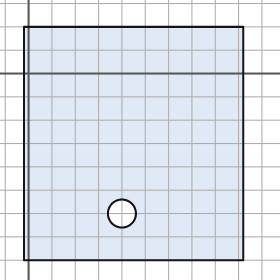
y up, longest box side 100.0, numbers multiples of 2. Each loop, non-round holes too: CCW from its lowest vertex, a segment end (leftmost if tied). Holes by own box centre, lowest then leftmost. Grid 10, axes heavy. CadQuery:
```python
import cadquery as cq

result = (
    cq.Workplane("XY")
    .moveTo(-2.0, -80.0)
    .lineTo(92.0, -80.0)
    .lineTo(92.0, 20.0)
    .lineTo(-2.0, 20.0)
    .close()
    .moveTo(40.0, -60.0)
    .circle(6.0)
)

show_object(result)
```